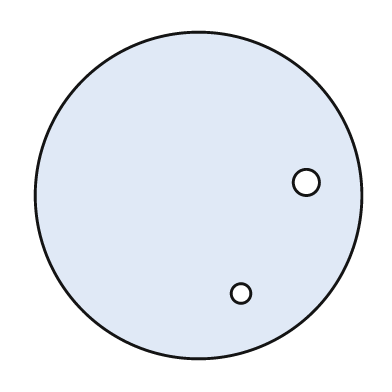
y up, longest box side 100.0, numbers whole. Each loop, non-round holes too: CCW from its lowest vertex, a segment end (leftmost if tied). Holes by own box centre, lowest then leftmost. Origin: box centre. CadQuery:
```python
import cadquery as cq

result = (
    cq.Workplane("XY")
    .moveTo(0.0, 0.0)
    .circle(50.0)
    .moveTo(13.0, -30.0)
    .circle(3.0)
    .moveTo(33.0, 4.0)
    .circle(4.0)
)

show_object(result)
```